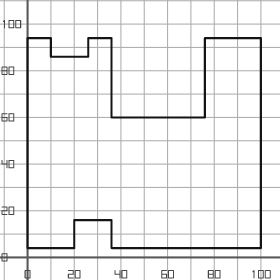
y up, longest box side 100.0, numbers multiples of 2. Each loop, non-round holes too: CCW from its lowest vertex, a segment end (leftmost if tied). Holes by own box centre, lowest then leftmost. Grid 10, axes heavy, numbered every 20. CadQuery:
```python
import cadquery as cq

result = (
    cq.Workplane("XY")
    .moveTo(0.0, 4.0)
    .lineTo(20.0, 4.0)
    .lineTo(20.0, 16.0)
    .lineTo(36.0, 16.0)
    .lineTo(36.0, 4.0)
    .lineTo(100.0, 4.0)
    .lineTo(100.0, 94.0)
    .lineTo(76.0, 94.0)
    .lineTo(76.0, 60.0)
    .lineTo(36.0, 60.0)
    .lineTo(36.0, 94.0)
    .lineTo(26.0, 94.0)
    .lineTo(26.0, 86.0)
    .lineTo(10.0, 86.0)
    .lineTo(10.0, 94.0)
    .lineTo(0.0, 94.0)
    .close()
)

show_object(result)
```